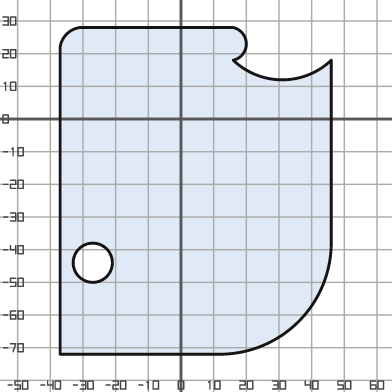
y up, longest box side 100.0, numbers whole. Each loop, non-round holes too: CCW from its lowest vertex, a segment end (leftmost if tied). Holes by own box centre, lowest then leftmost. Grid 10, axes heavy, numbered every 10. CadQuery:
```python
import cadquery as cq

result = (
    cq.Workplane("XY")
    .moveTo(-37.0, -72.0)
    .lineTo(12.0, -72.0)
    .threePointArc((36.0, -62.0), (46.0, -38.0))
    .lineTo(46.0, 18.0)
    .threePointArc((31.0, 12.0), (16.0, 18.0))
    .threePointArc((20.0, 23.0), (16.0, 28.0))
    .lineTo(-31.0, 28.0)
    .threePointArc((-35.0, 26.0), (-37.0, 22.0))
    .close()
    .moveTo(-27.0, -44.0)
    .circle(6.0)
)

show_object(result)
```